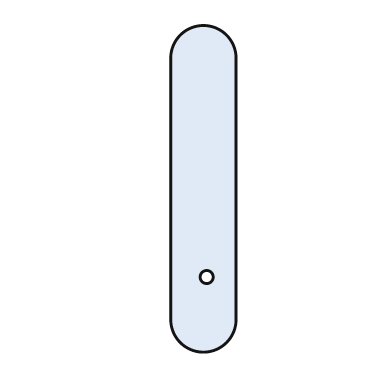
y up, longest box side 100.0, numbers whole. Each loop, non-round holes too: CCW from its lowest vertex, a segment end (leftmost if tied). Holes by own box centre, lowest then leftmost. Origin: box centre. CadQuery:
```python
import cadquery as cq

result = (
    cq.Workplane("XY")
    .moveTo(-10.0, -40.0)
    .threePointArc((0.0, -50.0), (10.0, -40.0))
    .lineTo(10.0, 40.0)
    .threePointArc((0.0, 50.0), (-10.0, 40.0))
    .close()
    .moveTo(1.0, -27.0)
    .circle(2.0)
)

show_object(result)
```